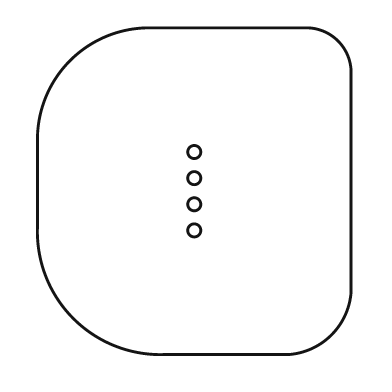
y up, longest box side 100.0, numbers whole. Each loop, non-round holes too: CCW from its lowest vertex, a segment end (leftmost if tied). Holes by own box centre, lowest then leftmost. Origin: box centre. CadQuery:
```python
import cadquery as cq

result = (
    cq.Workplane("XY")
    .moveTo(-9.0, -50.0)
    .lineTo(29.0, -50.0)
    .threePointArc((42.0, -44.0), (48.0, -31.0))
    .lineTo(48.0, 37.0)
    .threePointArc((44.0, 46.0), (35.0, 50.0))
    .lineTo(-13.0, 50.0)
    .threePointArc((-38.0, 40.0), (-48.0, 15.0))
    .lineTo(-48.0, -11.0)
    .threePointArc((-37.0, -39.0), (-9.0, -50.0))
    .close()
    .moveTo(0.0, -12.0)
    .circle(2.0)
    .moveTo(0.0, -4.0)
    .circle(2.0)
    .moveTo(0.0, 4.0)
    .circle(2.0)
    .moveTo(0.0, 12.0)
    .circle(2.0)
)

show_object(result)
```